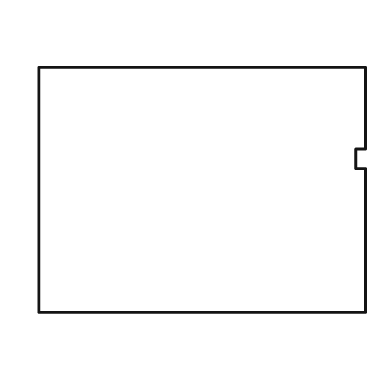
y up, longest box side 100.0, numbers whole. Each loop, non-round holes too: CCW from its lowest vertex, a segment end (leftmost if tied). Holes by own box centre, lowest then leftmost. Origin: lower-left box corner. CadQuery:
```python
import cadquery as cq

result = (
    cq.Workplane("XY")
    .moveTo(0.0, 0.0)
    .lineTo(100.0, 0.0)
    .lineTo(100.0, 44.0)
    .lineTo(97.0, 44.0)
    .lineTo(97.0, 50.0)
    .lineTo(100.0, 50.0)
    .lineTo(100.0, 75.0)
    .lineTo(0.0, 75.0)
    .close()
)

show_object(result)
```